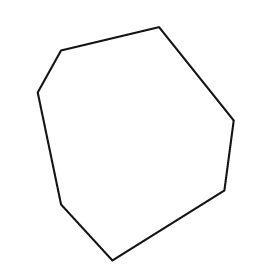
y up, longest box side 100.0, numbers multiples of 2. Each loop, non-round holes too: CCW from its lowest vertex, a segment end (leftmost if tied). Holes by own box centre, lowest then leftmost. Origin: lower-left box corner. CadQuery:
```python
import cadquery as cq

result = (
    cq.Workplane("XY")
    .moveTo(32.0, 0.0)
    .lineTo(80.0, 30.0)
    .lineTo(84.0, 60.0)
    .lineTo(52.0, 100.0)
    .lineTo(10.0, 90.0)
    .lineTo(0.0, 72.0)
    .lineTo(10.0, 24.0)
    .close()
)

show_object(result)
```